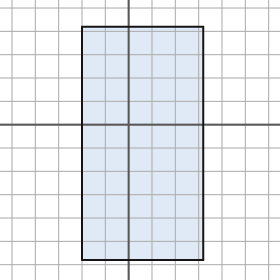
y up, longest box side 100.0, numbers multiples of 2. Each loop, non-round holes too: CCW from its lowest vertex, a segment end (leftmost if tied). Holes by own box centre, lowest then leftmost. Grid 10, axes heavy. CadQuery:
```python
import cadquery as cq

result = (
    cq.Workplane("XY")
    .moveTo(-20.0, -58.0)
    .lineTo(32.0, -58.0)
    .lineTo(32.0, 42.0)
    .lineTo(-20.0, 42.0)
    .close()
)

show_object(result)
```